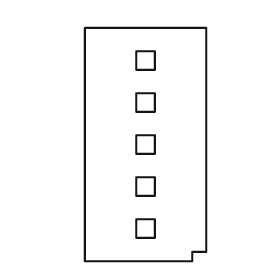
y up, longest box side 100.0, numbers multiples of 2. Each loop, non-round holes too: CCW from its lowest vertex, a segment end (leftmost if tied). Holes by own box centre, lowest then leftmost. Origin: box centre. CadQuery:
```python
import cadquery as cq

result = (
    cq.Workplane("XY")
    .moveTo(-26.0, -50.0)
    .lineTo(20.0, -50.0)
    .lineTo(20.0, -46.0)
    .lineTo(26.0, -46.0)
    .lineTo(26.0, 50.0)
    .lineTo(-26.0, 50.0)
    .close()
    .moveTo(-4.0, -40.0)
    .lineTo(4.0, -40.0)
    .lineTo(4.0, -32.0)
    .lineTo(-4.0, -32.0)
    .close()
    .moveTo(-4.0, -22.0)
    .lineTo(4.0, -22.0)
    .lineTo(4.0, -14.0)
    .lineTo(-4.0, -14.0)
    .close()
    .moveTo(-4.0, -4.0)
    .lineTo(4.0, -4.0)
    .lineTo(4.0, 4.0)
    .lineTo(-4.0, 4.0)
    .close()
    .moveTo(-4.0, 14.0)
    .lineTo(4.0, 14.0)
    .lineTo(4.0, 22.0)
    .lineTo(-4.0, 22.0)
    .close()
    .moveTo(-4.0, 32.0)
    .lineTo(4.0, 32.0)
    .lineTo(4.0, 40.0)
    .lineTo(-4.0, 40.0)
    .close()
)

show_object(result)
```